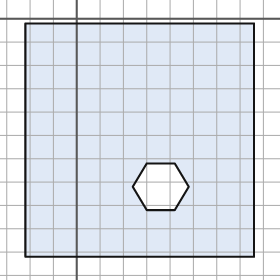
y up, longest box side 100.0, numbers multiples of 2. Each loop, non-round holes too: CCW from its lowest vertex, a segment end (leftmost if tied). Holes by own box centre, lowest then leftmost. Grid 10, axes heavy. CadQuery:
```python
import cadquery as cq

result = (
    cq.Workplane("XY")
    .moveTo(-22.0, -102.0)
    .lineTo(76.0, -102.0)
    .lineTo(76.0, -2.0)
    .lineTo(-22.0, -2.0)
    .close()
    .moveTo(30.0, -82.0)
    .lineTo(42.0, -82.0)
    .lineTo(48.0, -72.0)
    .lineTo(42.0, -62.0)
    .lineTo(30.0, -62.0)
    .lineTo(24.0, -72.0)
    .close()
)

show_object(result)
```